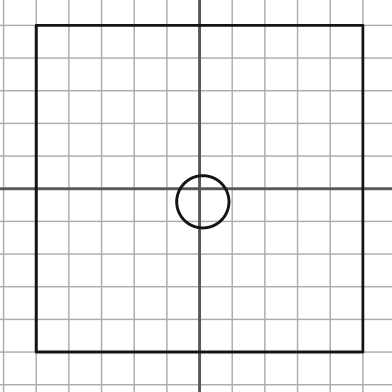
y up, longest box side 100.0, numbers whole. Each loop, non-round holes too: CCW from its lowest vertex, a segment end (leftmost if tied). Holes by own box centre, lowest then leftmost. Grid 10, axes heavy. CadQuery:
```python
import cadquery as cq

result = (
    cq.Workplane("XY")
    .moveTo(-50.0, -50.0)
    .lineTo(50.0, -50.0)
    .lineTo(50.0, 50.0)
    .lineTo(-50.0, 50.0)
    .close()
    .moveTo(1.0, -4.0)
    .circle(8.0)
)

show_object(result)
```